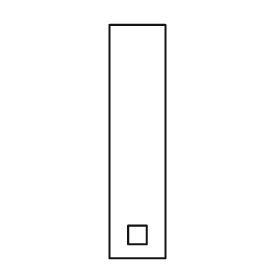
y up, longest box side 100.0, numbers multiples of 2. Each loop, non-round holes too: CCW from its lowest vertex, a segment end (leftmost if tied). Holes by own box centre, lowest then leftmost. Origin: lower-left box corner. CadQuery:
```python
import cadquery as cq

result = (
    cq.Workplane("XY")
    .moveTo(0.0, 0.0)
    .lineTo(24.0, 0.0)
    .lineTo(24.0, 100.0)
    .lineTo(0.0, 100.0)
    .close()
    .moveTo(8.0, 6.0)
    .lineTo(16.0, 6.0)
    .lineTo(16.0, 14.0)
    .lineTo(8.0, 14.0)
    .close()
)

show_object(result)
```